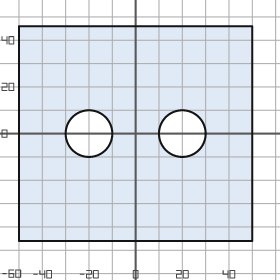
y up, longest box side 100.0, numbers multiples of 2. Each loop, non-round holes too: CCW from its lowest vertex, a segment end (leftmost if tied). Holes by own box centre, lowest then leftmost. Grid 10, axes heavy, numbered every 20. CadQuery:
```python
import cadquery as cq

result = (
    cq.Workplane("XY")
    .moveTo(-50.0, -46.0)
    .lineTo(50.0, -46.0)
    .lineTo(50.0, 46.0)
    .lineTo(-50.0, 46.0)
    .close()
    .moveTo(-20.0, 0.0)
    .circle(10.0)
    .moveTo(20.0, 0.0)
    .circle(10.0)
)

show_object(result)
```